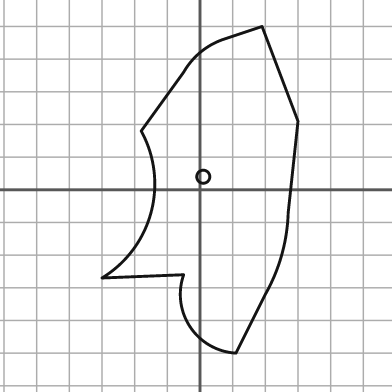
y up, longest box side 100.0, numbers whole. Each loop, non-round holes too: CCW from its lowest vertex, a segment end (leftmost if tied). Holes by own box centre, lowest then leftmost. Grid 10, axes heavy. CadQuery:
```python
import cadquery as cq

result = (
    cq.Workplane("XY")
    .moveTo(11.0, -50.0)
    .lineTo(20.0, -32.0)
    .threePointArc((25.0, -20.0), (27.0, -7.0))
    .lineTo(30.0, 21.0)
    .lineTo(19.0, 50.0)
    .lineTo(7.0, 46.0)
    .threePointArc((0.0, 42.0), (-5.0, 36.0))
    .lineTo(-18.0, 18.0)
    .threePointArc((-15.0, -7.0), (-30.0, -27.0))
    .lineTo(-5.0, -26.0)
    .threePointArc((-3.0, -42.0), (11.0, -50.0))
    .close()
    .moveTo(1.0, 4.0)
    .circle(2.0)
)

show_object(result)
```